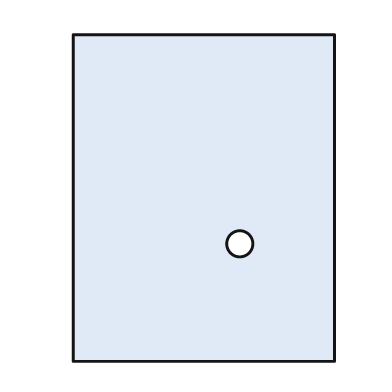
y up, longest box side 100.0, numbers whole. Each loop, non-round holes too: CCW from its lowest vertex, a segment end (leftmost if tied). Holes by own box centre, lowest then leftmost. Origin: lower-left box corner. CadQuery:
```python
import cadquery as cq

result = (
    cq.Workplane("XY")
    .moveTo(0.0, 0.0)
    .lineTo(80.0, 0.0)
    .lineTo(80.0, 100.0)
    .lineTo(0.0, 100.0)
    .close()
    .moveTo(51.0, 36.0)
    .circle(4.0)
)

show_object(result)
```